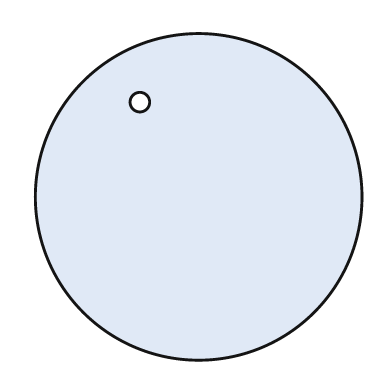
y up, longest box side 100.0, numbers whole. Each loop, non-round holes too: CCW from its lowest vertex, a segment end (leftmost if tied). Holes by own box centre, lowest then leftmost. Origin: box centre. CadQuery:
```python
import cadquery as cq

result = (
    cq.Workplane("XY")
    .moveTo(0.0, 0.0)
    .circle(50.0)
    .moveTo(-18.0, 29.0)
    .circle(3.0)
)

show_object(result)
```